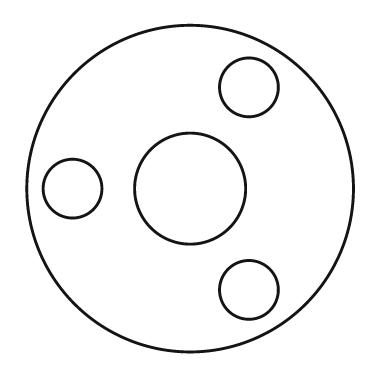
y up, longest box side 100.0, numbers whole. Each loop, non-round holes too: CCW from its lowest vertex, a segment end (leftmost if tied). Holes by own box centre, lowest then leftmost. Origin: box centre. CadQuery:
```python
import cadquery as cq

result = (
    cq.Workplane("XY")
    .moveTo(0.0, 0.0)
    .circle(50.0)
    .moveTo(18.0, -31.0)
    .circle(9.0)
    .moveTo(-36.0, 0.0)
    .circle(9.0)
    .moveTo(0.0, 0.0)
    .circle(17.0)
    .moveTo(18.0, 31.0)
    .circle(9.0)
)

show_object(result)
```